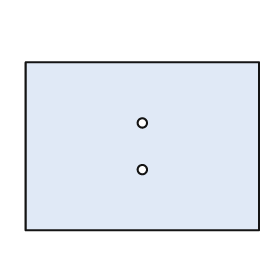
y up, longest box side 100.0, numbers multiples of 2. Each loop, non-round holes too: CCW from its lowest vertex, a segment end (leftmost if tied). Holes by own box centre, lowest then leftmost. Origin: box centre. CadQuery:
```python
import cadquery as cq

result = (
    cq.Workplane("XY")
    .moveTo(-50.0, -36.0)
    .lineTo(50.0, -36.0)
    .lineTo(50.0, 36.0)
    .lineTo(-50.0, 36.0)
    .close()
    .moveTo(0.0, -10.0)
    .circle(2.0)
    .moveTo(0.0, 10.0)
    .circle(2.0)
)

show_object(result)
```